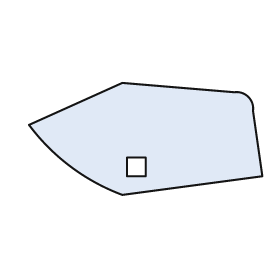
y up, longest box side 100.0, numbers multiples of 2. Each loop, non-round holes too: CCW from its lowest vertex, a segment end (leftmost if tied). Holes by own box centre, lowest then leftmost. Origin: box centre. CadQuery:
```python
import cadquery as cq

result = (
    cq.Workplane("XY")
    .moveTo(-10.0, -24.0)
    .lineTo(50.0, -16.0)
    .lineTo(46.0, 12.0)
    .threePointArc((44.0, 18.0), (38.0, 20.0))
    .lineTo(-10.0, 24.0)
    .lineTo(-50.0, 6.0)
    .threePointArc((-32.0, -12.0), (-10.0, -24.0))
    .close()
    .moveTo(-8.0, -16.0)
    .lineTo(0.0, -16.0)
    .lineTo(0.0, -8.0)
    .lineTo(-8.0, -8.0)
    .close()
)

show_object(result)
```